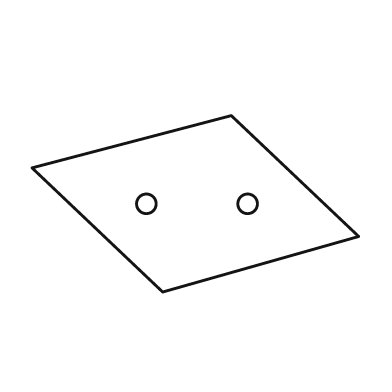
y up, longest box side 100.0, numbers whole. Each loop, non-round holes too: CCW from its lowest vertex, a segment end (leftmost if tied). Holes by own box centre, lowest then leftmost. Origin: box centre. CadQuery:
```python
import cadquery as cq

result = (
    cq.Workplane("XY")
    .moveTo(-10.0, -27.0)
    .lineTo(50.0, -10.0)
    .lineTo(11.0, 27.0)
    .lineTo(-50.0, 11.0)
    .close()
    .moveTo(-15.0, 0.0)
    .circle(3.0)
    .moveTo(16.0, 0.0)
    .circle(3.0)
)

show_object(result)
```